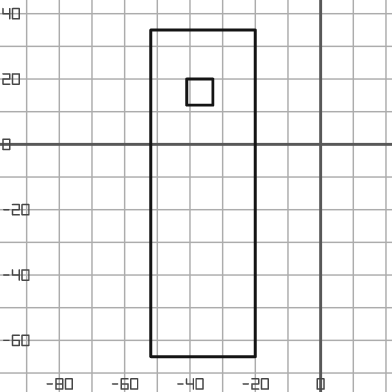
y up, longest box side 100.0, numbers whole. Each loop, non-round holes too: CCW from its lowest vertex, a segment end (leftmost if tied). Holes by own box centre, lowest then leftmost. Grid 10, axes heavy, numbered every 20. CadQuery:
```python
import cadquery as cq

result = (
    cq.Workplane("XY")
    .moveTo(-52.0, -65.0)
    .lineTo(-20.0, -65.0)
    .lineTo(-20.0, 35.0)
    .lineTo(-52.0, 35.0)
    .close()
    .moveTo(-41.0, 12.0)
    .lineTo(-33.0, 12.0)
    .lineTo(-33.0, 20.0)
    .lineTo(-41.0, 20.0)
    .close()
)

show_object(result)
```